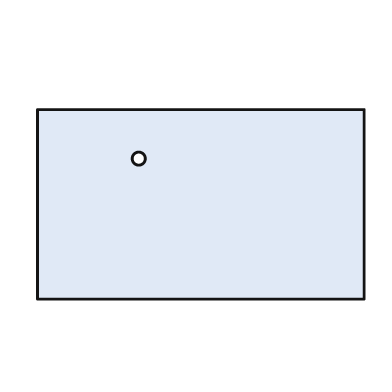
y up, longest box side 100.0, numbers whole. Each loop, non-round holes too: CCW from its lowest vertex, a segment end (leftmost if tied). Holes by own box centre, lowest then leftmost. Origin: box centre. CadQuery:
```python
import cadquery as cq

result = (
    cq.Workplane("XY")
    .moveTo(-50.0, -29.0)
    .lineTo(50.0, -29.0)
    .lineTo(50.0, 29.0)
    .lineTo(-50.0, 29.0)
    .close()
    .moveTo(-19.0, 14.0)
    .circle(2.0)
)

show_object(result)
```